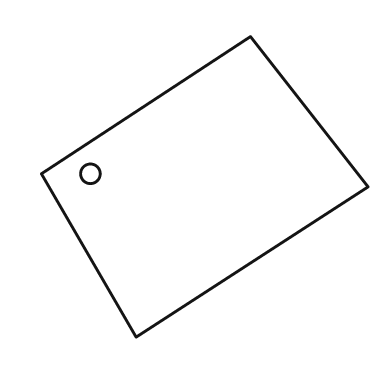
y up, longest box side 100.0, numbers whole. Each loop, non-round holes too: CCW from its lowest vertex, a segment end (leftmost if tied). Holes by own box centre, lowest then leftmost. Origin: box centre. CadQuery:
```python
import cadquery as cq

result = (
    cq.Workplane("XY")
    .moveTo(-21.0, -46.0)
    .lineTo(50.0, 0.0)
    .lineTo(14.0, 46.0)
    .lineTo(-50.0, 4.0)
    .close()
    .moveTo(-35.0, 4.0)
    .circle(3.0)
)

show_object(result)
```